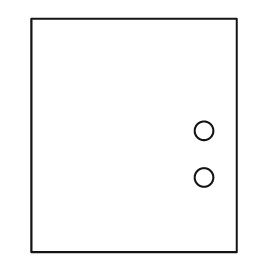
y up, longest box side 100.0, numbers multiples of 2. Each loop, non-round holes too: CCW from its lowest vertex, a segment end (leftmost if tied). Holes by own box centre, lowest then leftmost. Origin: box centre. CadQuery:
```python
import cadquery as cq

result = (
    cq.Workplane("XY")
    .moveTo(-44.0, -50.0)
    .lineTo(44.0, -50.0)
    .lineTo(44.0, 50.0)
    .lineTo(-44.0, 50.0)
    .close()
    .moveTo(30.0, -18.0)
    .circle(4.0)
    .moveTo(30.0, 2.0)
    .circle(4.0)
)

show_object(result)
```